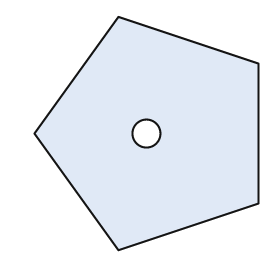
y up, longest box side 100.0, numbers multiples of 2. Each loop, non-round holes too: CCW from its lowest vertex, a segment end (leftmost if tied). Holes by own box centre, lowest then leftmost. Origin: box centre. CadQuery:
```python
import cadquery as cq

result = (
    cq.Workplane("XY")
    .moveTo(-12.0, -50.0)
    .lineTo(48.0, -30.0)
    .lineTo(48.0, 30.0)
    .lineTo(-12.0, 50.0)
    .lineTo(-48.0, 0.0)
    .close()
    .moveTo(0.0, 0.0)
    .circle(6.0)
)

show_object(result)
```